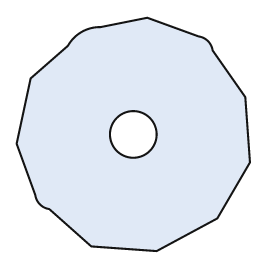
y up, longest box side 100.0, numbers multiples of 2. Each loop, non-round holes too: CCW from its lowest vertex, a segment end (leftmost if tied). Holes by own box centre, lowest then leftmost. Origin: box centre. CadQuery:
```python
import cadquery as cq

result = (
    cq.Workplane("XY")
    .moveTo(10.0, -50.0)
    .lineTo(36.0, -36.0)
    .lineTo(50.0, -12.0)
    .lineTo(48.0, 16.0)
    .lineTo(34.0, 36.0)
    .threePointArc((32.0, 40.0), (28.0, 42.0))
    .lineTo(6.0, 50.0)
    .lineTo(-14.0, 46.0)
    .threePointArc((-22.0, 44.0), (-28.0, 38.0))
    .lineTo(-44.0, 24.0)
    .lineTo(-50.0, -4.0)
    .lineTo(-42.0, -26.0)
    .threePointArc((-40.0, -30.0), (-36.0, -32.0))
    .lineTo(-18.0, -48.0)
    .close()
    .moveTo(0.0, 0.0)
    .circle(10.0)
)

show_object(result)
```